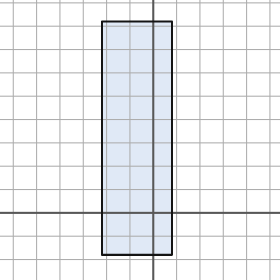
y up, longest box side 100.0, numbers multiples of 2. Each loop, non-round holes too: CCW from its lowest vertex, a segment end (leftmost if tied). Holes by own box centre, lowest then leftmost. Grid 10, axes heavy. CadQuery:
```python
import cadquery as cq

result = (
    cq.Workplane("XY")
    .moveTo(-22.0, -18.0)
    .lineTo(8.0, -18.0)
    .lineTo(8.0, 82.0)
    .lineTo(-22.0, 82.0)
    .close()
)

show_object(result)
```